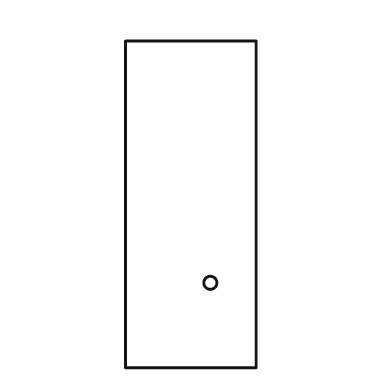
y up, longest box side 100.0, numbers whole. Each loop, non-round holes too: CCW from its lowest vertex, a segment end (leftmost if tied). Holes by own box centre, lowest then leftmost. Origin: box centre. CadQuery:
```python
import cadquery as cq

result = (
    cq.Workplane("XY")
    .moveTo(-20.0, -50.0)
    .lineTo(20.0, -50.0)
    .lineTo(20.0, 50.0)
    .lineTo(-20.0, 50.0)
    .close()
    .moveTo(6.0, -24.0)
    .circle(2.0)
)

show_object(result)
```